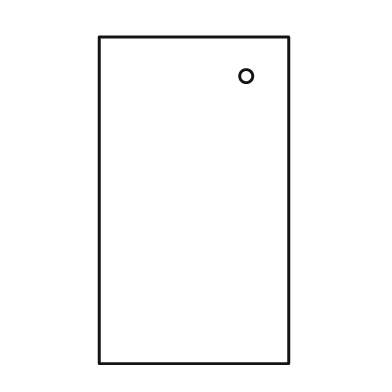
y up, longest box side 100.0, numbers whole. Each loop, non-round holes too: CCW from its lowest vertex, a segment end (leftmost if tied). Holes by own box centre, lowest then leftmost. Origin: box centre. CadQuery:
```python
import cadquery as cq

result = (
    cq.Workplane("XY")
    .moveTo(-29.0, -50.0)
    .lineTo(29.0, -50.0)
    .lineTo(29.0, 50.0)
    .lineTo(-29.0, 50.0)
    .close()
    .moveTo(16.0, 38.0)
    .circle(2.0)
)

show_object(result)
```